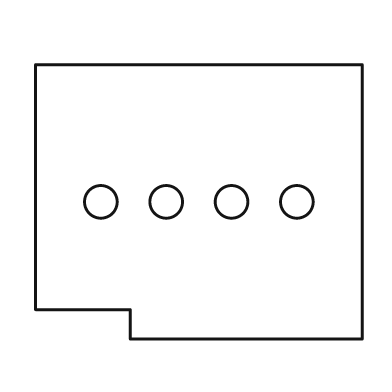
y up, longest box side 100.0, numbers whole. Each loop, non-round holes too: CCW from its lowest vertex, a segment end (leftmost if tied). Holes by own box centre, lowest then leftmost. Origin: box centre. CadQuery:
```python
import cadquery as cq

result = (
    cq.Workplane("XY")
    .moveTo(-21.0, -42.0)
    .lineTo(50.0, -42.0)
    .lineTo(50.0, 42.0)
    .lineTo(-50.0, 42.0)
    .lineTo(-50.0, -33.0)
    .lineTo(-21.0, -33.0)
    .close()
    .moveTo(-30.0, 0.0)
    .circle(5.0)
    .moveTo(-10.0, 0.0)
    .circle(5.0)
    .moveTo(10.0, 0.0)
    .circle(5.0)
    .moveTo(30.0, 0.0)
    .circle(5.0)
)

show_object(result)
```